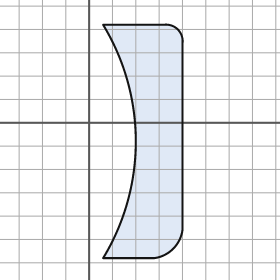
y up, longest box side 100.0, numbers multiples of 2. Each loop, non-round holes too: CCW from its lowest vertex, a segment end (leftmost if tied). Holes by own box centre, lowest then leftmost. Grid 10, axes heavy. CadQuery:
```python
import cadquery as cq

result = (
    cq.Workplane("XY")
    .moveTo(6.0, -58.0)
    .lineTo(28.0, -58.0)
    .threePointArc((36.0, -54.0), (40.0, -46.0))
    .lineTo(40.0, 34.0)
    .threePointArc((38.0, 40.0), (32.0, 42.0))
    .lineTo(6.0, 42.0)
    .threePointArc((20.0, -8.0), (6.0, -58.0))
    .close()
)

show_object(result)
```